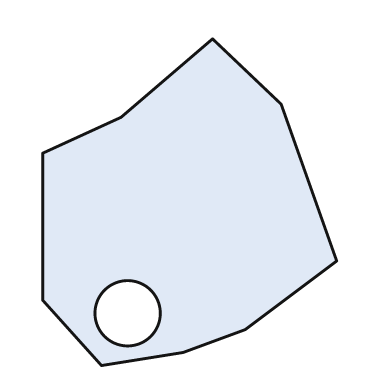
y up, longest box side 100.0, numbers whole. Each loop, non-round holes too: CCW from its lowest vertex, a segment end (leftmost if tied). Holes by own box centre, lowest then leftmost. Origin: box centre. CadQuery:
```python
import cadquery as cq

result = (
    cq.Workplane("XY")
    .moveTo(-27.0, -50.0)
    .lineTo(-2.0, -46.0)
    .lineTo(17.0, -39.0)
    .lineTo(45.0, -18.0)
    .lineTo(28.0, 30.0)
    .lineTo(7.0, 50.0)
    .lineTo(-21.0, 26.0)
    .lineTo(-45.0, 15.0)
    .lineTo(-45.0, -30.0)
    .close()
    .moveTo(-19.0, -34.0)
    .circle(10.0)
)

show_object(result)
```